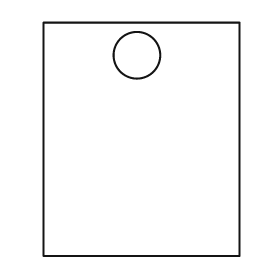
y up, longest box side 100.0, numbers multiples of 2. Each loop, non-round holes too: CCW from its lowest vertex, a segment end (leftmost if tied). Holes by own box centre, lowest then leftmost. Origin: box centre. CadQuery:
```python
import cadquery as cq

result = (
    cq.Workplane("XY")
    .moveTo(-42.0, -50.0)
    .lineTo(42.0, -50.0)
    .lineTo(42.0, 50.0)
    .lineTo(-42.0, 50.0)
    .close()
    .moveTo(-2.0, 36.0)
    .circle(10.0)
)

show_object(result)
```